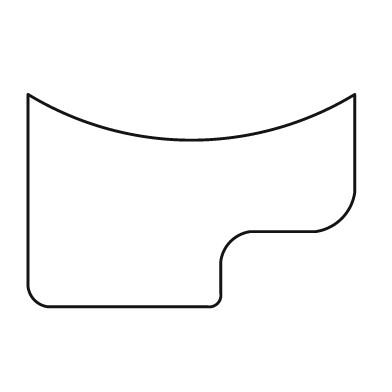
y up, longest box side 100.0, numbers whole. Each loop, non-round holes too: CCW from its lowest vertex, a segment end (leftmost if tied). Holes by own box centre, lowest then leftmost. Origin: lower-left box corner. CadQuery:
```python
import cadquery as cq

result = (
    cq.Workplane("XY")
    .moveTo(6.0, 0.0)
    .lineTo(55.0, 0.0)
    .threePointArc((58.0, 1.0), (59.0, 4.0))
    .lineTo(59.0, 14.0)
    .threePointArc((62.0, 20.0), (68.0, 23.0))
    .lineTo(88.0, 23.0)
    .threePointArc((96.0, 27.0), (100.0, 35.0))
    .lineTo(100.0, 65.0)
    .threePointArc((50.0, 51.0), (0.0, 65.0))
    .lineTo(0.0, 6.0)
    .threePointArc((2.0, 2.0), (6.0, 0.0))
    .close()
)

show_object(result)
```